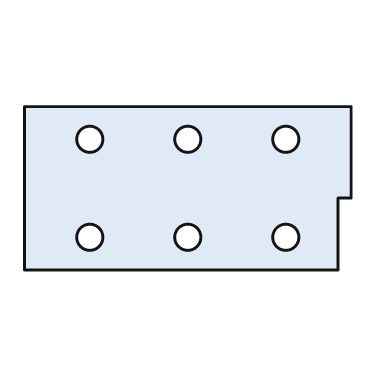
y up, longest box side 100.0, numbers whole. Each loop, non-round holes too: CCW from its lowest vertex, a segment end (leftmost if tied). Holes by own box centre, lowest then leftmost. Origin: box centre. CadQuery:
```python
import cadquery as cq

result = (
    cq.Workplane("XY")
    .moveTo(-50.0, -25.0)
    .lineTo(46.0, -25.0)
    .lineTo(46.0, -3.0)
    .lineTo(50.0, -3.0)
    .lineTo(50.0, 25.0)
    .lineTo(-50.0, 25.0)
    .close()
    .moveTo(-30.0, -15.0)
    .circle(4.0)
    .moveTo(0.0, -15.0)
    .circle(4.0)
    .moveTo(30.0, -15.0)
    .circle(4.0)
    .moveTo(-30.0, 15.0)
    .circle(4.0)
    .moveTo(0.0, 15.0)
    .circle(4.0)
    .moveTo(30.0, 15.0)
    .circle(4.0)
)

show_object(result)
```